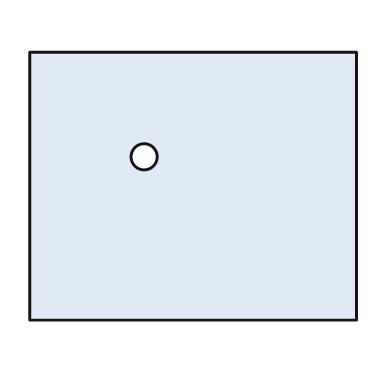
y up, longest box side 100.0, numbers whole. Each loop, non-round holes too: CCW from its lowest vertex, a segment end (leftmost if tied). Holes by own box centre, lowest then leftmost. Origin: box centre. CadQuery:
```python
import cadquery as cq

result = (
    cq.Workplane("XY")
    .moveTo(-50.0, -41.0)
    .lineTo(50.0, -41.0)
    .lineTo(50.0, 41.0)
    .lineTo(-50.0, 41.0)
    .close()
    .moveTo(-15.0, 9.0)
    .circle(4.0)
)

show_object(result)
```